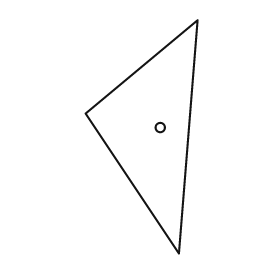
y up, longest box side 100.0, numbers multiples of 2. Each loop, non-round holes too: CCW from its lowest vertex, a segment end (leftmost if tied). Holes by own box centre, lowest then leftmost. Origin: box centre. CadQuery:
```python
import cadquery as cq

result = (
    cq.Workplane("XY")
    .moveTo(16.0, -50.0)
    .lineTo(24.0, 50.0)
    .lineTo(-24.0, 10.0)
    .close()
    .moveTo(8.0, 4.0)
    .circle(2.0)
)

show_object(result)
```